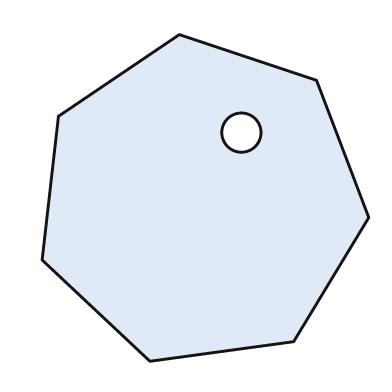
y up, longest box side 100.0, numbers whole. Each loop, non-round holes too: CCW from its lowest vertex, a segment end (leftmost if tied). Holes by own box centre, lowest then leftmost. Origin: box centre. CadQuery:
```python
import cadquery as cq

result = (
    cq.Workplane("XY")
    .moveTo(-17.0, -50.0)
    .lineTo(27.0, -44.0)
    .lineTo(50.0, -6.0)
    .lineTo(34.0, 36.0)
    .lineTo(-8.0, 50.0)
    .lineTo(-45.0, 25.0)
    .lineTo(-50.0, -19.0)
    .close()
    .moveTo(11.0, 20.0)
    .circle(6.0)
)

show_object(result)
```